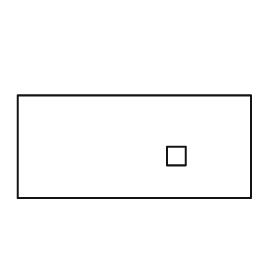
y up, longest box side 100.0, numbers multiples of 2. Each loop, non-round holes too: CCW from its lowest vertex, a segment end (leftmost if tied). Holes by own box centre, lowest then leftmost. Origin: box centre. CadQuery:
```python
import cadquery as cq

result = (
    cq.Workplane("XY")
    .moveTo(-50.0, -22.0)
    .lineTo(50.0, -22.0)
    .lineTo(50.0, 22.0)
    .lineTo(-50.0, 22.0)
    .close()
    .moveTo(14.0, -8.0)
    .lineTo(22.0, -8.0)
    .lineTo(22.0, 0.0)
    .lineTo(14.0, 0.0)
    .close()
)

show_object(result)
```